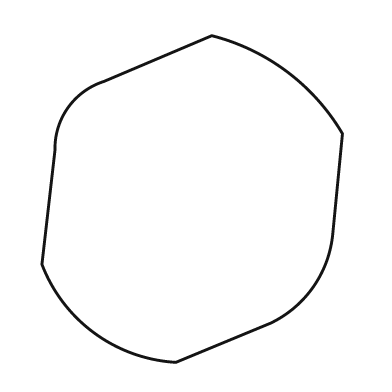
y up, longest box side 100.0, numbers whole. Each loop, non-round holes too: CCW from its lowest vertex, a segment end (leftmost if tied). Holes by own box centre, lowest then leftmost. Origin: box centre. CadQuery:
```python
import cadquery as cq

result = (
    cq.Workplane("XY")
    .moveTo(-5.0, -50.0)
    .lineTo(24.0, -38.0)
    .threePointArc((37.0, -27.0), (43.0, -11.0))
    .lineTo(46.0, 20.0)
    .threePointArc((29.0, 39.0), (6.0, 50.0))
    .lineTo(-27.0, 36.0)
    .threePointArc((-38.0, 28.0), (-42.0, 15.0))
    .lineTo(-46.0, -20.0)
    .threePointArc((-30.0, -41.0), (-5.0, -50.0))
    .close()
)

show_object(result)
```